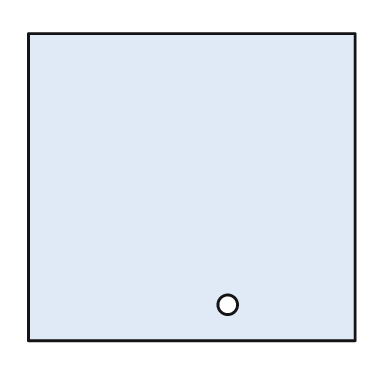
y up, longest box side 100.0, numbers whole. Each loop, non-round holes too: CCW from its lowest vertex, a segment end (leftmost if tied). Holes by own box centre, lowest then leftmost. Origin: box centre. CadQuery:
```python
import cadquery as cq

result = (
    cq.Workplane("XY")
    .moveTo(-50.0, -47.0)
    .lineTo(50.0, -47.0)
    .lineTo(50.0, 47.0)
    .lineTo(-50.0, 47.0)
    .close()
    .moveTo(11.0, -36.0)
    .circle(3.0)
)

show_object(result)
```